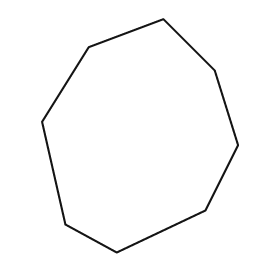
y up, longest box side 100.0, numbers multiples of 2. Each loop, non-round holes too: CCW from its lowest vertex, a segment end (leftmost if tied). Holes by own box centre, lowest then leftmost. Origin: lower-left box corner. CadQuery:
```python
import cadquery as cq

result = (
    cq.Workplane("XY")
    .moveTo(32.0, 0.0)
    .lineTo(70.0, 18.0)
    .lineTo(84.0, 46.0)
    .lineTo(74.0, 78.0)
    .lineTo(52.0, 100.0)
    .lineTo(20.0, 88.0)
    .lineTo(0.0, 56.0)
    .lineTo(10.0, 12.0)
    .close()
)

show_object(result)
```